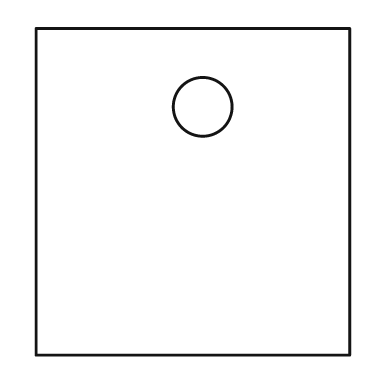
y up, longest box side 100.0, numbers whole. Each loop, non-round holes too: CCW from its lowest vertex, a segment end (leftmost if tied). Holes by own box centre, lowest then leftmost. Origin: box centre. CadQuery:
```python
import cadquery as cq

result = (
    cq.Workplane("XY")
    .moveTo(-48.0, -50.0)
    .lineTo(48.0, -50.0)
    .lineTo(48.0, 50.0)
    .lineTo(-48.0, 50.0)
    .close()
    .moveTo(3.0, 26.0)
    .circle(9.0)
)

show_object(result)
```